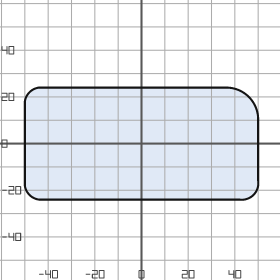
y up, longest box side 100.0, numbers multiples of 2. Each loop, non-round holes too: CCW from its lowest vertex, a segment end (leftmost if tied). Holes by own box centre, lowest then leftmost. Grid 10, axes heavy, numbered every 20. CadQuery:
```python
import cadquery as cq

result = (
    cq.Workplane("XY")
    .moveTo(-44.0, -24.0)
    .lineTo(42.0, -24.0)
    .threePointArc((48.0, -22.0), (50.0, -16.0))
    .lineTo(50.0, 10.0)
    .threePointArc((46.0, 20.0), (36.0, 24.0))
    .lineTo(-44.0, 24.0)
    .threePointArc((-48.0, 22.0), (-50.0, 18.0))
    .lineTo(-50.0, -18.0)
    .threePointArc((-48.0, -22.0), (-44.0, -24.0))
    .close()
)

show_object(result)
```